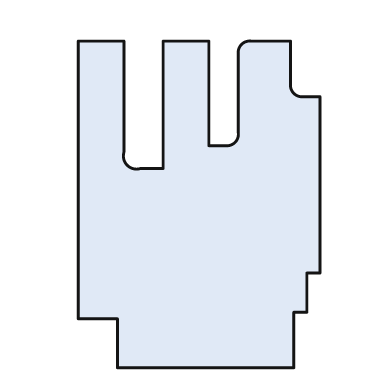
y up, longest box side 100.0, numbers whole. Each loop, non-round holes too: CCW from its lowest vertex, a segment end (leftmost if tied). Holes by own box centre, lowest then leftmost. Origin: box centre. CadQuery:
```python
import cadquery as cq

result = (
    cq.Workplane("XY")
    .moveTo(-25.0, -50.0)
    .lineTo(29.0, -50.0)
    .lineTo(29.0, -33.0)
    .lineTo(33.0, -33.0)
    .lineTo(33.0, -21.0)
    .lineTo(37.0, -21.0)
    .lineTo(37.0, 33.0)
    .lineTo(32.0, 33.0)
    .threePointArc((29.0, 34.0), (28.0, 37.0))
    .lineTo(28.0, 50.0)
    .lineTo(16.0, 50.0)
    .threePointArc((13.0, 49.0), (12.0, 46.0))
    .lineTo(12.0, 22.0)
    .threePointArc((11.0, 19.0), (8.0, 18.0))
    .lineTo(3.0, 18.0)
    .lineTo(3.0, 50.0)
    .lineTo(-11.0, 50.0)
    .lineTo(-11.0, 11.0)
    .lineTo(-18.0, 11.0)
    .threePointArc((-22.0, 12.0), (-23.0, 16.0))
    .lineTo(-23.0, 50.0)
    .lineTo(-37.0, 50.0)
    .lineTo(-37.0, -35.0)
    .lineTo(-25.0, -35.0)
    .close()
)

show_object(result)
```